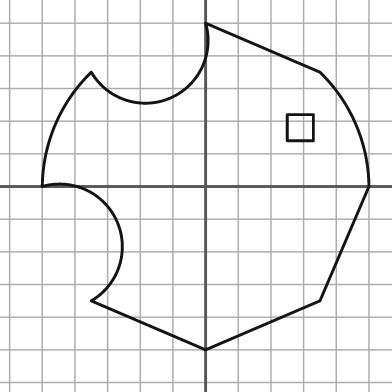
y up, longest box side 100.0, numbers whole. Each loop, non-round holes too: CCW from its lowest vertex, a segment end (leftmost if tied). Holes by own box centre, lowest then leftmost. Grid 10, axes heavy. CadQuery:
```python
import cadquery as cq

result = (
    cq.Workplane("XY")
    .moveTo(0.0, -50.0)
    .lineTo(35.0, -35.0)
    .lineTo(50.0, 0.0)
    .threePointArc((46.0, 19.0), (35.0, 35.0))
    .lineTo(0.0, 50.0)
    .threePointArc((-11.0, 27.0), (-35.0, 35.0))
    .threePointArc((-46.0, 19.0), (-50.0, 0.0))
    .threePointArc((-27.0, -11.0), (-35.0, -35.0))
    .close()
    .moveTo(25.0, 14.0)
    .lineTo(33.0, 14.0)
    .lineTo(33.0, 22.0)
    .lineTo(25.0, 22.0)
    .close()
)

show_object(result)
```